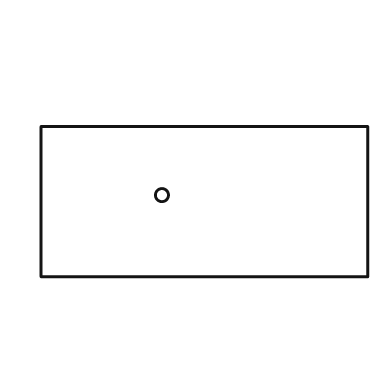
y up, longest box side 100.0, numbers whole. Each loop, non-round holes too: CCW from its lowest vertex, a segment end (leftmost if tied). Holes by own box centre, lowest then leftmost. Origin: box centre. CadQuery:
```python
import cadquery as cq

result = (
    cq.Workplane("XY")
    .moveTo(-50.0, -23.0)
    .lineTo(50.0, -23.0)
    .lineTo(50.0, 23.0)
    .lineTo(-50.0, 23.0)
    .close()
    .moveTo(-13.0, 2.0)
    .circle(2.0)
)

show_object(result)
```